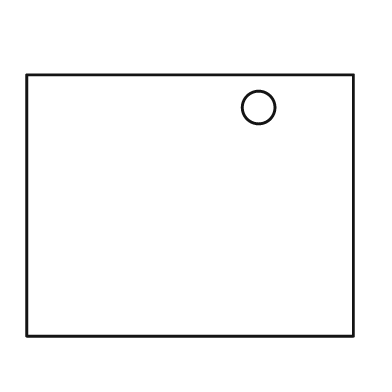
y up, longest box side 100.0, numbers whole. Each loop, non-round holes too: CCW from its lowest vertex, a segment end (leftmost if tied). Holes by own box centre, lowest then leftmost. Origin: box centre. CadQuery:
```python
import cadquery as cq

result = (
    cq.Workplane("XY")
    .moveTo(-50.0, -40.0)
    .lineTo(50.0, -40.0)
    .lineTo(50.0, 40.0)
    .lineTo(-50.0, 40.0)
    .close()
    .moveTo(21.0, 30.0)
    .circle(5.0)
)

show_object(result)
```